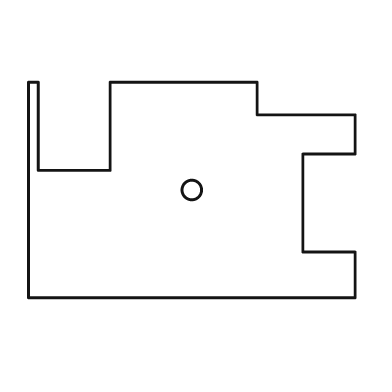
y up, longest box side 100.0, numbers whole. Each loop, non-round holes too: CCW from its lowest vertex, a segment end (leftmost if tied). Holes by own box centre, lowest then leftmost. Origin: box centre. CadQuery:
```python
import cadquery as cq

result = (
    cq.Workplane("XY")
    .moveTo(-50.0, -33.0)
    .lineTo(50.0, -33.0)
    .lineTo(50.0, -19.0)
    .lineTo(34.0, -19.0)
    .lineTo(34.0, 11.0)
    .lineTo(50.0, 11.0)
    .lineTo(50.0, 23.0)
    .lineTo(20.0, 23.0)
    .lineTo(20.0, 33.0)
    .lineTo(-25.0, 33.0)
    .lineTo(-25.0, 6.0)
    .lineTo(-47.0, 6.0)
    .lineTo(-47.0, 33.0)
    .lineTo(-50.0, 33.0)
    .close()
    .moveTo(0.0, 0.0)
    .circle(3.0)
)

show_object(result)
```